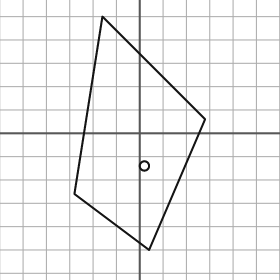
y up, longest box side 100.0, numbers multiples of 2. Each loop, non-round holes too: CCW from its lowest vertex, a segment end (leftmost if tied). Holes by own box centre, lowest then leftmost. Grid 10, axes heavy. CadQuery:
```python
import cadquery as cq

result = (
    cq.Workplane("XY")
    .moveTo(4.0, -50.0)
    .lineTo(28.0, 6.0)
    .lineTo(-16.0, 50.0)
    .lineTo(-28.0, -26.0)
    .close()
    .moveTo(2.0, -14.0)
    .circle(2.0)
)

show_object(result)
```